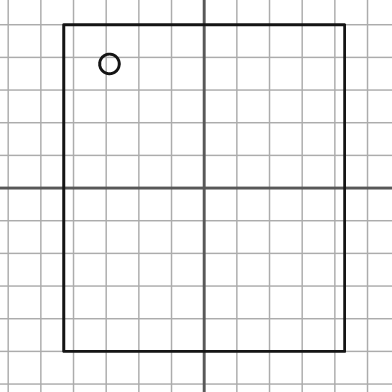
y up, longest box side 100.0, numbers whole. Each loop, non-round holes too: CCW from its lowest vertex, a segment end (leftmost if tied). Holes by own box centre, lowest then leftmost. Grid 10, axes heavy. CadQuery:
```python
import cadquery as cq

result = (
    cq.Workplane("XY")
    .moveTo(-43.0, -50.0)
    .lineTo(43.0, -50.0)
    .lineTo(43.0, 50.0)
    .lineTo(-43.0, 50.0)
    .close()
    .moveTo(-29.0, 38.0)
    .circle(3.0)
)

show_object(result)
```